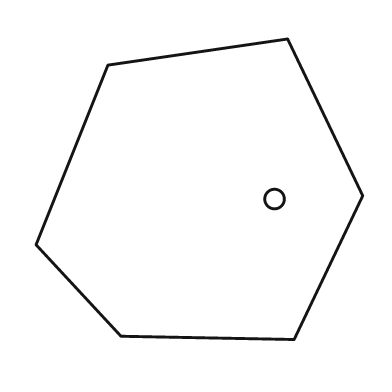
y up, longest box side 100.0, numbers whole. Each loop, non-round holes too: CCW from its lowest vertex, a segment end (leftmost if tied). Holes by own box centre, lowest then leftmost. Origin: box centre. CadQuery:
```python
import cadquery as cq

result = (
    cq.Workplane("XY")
    .moveTo(29.0, -46.0)
    .lineTo(50.0, -2.0)
    .lineTo(27.0, 46.0)
    .lineTo(-28.0, 38.0)
    .lineTo(-50.0, -17.0)
    .lineTo(-24.0, -45.0)
    .close()
    .moveTo(23.0, -3.0)
    .circle(3.0)
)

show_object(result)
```